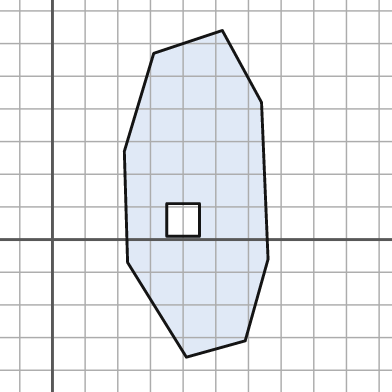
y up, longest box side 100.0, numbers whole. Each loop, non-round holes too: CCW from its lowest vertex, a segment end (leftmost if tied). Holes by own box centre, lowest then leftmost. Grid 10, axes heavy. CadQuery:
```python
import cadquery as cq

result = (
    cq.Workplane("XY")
    .moveTo(41.0, -36.0)
    .lineTo(59.0, -31.0)
    .lineTo(66.0, -6.0)
    .lineTo(64.0, 42.0)
    .lineTo(52.0, 64.0)
    .lineTo(31.0, 57.0)
    .lineTo(22.0, 27.0)
    .lineTo(23.0, -7.0)
    .close()
    .moveTo(35.0, 1.0)
    .lineTo(45.0, 1.0)
    .lineTo(45.0, 11.0)
    .lineTo(35.0, 11.0)
    .close()
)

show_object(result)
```